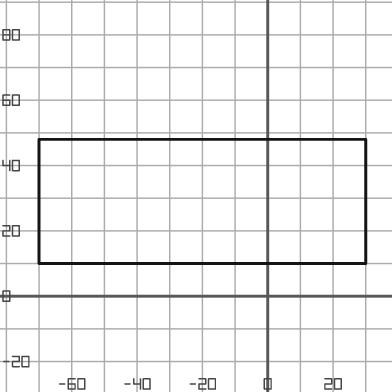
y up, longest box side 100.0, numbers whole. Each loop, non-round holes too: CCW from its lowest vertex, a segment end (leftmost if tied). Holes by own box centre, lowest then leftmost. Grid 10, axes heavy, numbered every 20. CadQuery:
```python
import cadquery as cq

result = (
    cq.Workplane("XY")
    .moveTo(-70.0, 10.0)
    .lineTo(30.0, 10.0)
    .lineTo(30.0, 48.0)
    .lineTo(-70.0, 48.0)
    .close()
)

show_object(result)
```